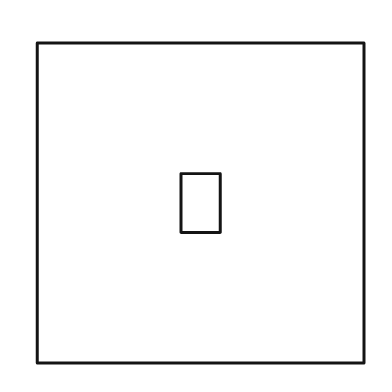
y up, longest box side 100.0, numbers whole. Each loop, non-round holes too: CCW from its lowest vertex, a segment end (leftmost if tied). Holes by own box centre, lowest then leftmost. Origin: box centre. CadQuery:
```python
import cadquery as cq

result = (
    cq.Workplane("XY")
    .moveTo(-50.0, -49.0)
    .lineTo(50.0, -49.0)
    .lineTo(50.0, 49.0)
    .lineTo(-50.0, 49.0)
    .close()
    .moveTo(-6.0, -9.0)
    .lineTo(6.0, -9.0)
    .lineTo(6.0, 9.0)
    .lineTo(-6.0, 9.0)
    .close()
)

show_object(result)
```